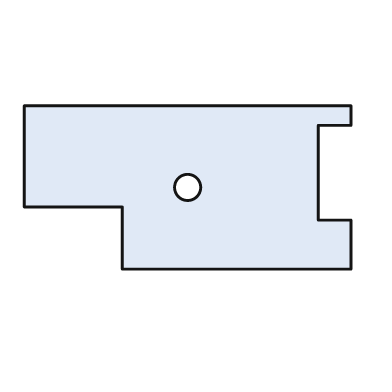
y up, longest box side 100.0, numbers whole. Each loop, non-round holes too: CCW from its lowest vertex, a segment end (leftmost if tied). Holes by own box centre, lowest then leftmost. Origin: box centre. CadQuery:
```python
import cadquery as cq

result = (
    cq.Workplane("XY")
    .moveTo(-20.0, -25.0)
    .lineTo(50.0, -25.0)
    .lineTo(50.0, -10.0)
    .lineTo(40.0, -10.0)
    .lineTo(40.0, 19.0)
    .lineTo(50.0, 19.0)
    .lineTo(50.0, 25.0)
    .lineTo(-50.0, 25.0)
    .lineTo(-50.0, -6.0)
    .lineTo(-20.0, -6.0)
    .close()
    .moveTo(0.0, 0.0)
    .circle(4.0)
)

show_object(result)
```